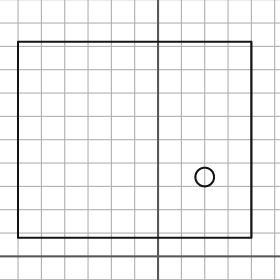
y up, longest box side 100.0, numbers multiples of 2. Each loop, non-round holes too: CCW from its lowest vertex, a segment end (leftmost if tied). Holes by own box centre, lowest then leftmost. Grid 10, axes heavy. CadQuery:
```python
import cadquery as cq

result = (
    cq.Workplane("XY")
    .moveTo(-60.0, 8.0)
    .lineTo(40.0, 8.0)
    .lineTo(40.0, 92.0)
    .lineTo(-60.0, 92.0)
    .close()
    .moveTo(20.0, 34.0)
    .circle(4.0)
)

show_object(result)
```